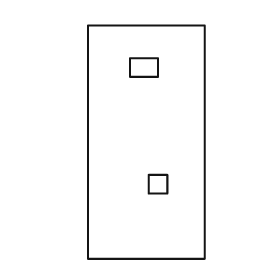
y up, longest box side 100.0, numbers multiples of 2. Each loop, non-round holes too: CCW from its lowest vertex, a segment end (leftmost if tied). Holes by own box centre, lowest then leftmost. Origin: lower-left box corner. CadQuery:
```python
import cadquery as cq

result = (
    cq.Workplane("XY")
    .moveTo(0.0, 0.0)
    .lineTo(50.0, 0.0)
    .lineTo(50.0, 100.0)
    .lineTo(0.0, 100.0)
    .close()
    .moveTo(26.0, 28.0)
    .lineTo(34.0, 28.0)
    .lineTo(34.0, 36.0)
    .lineTo(26.0, 36.0)
    .close()
    .moveTo(18.0, 78.0)
    .lineTo(30.0, 78.0)
    .lineTo(30.0, 86.0)
    .lineTo(18.0, 86.0)
    .close()
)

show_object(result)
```